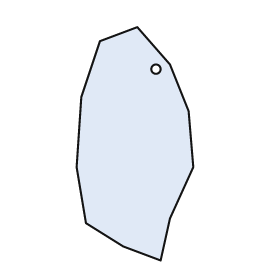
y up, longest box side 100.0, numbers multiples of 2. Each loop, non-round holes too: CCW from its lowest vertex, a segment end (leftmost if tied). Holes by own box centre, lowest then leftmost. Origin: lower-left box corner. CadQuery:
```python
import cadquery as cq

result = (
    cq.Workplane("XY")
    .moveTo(36.0, 0.0)
    .lineTo(40.0, 18.0)
    .lineTo(50.0, 40.0)
    .lineTo(48.0, 64.0)
    .lineTo(40.0, 84.0)
    .lineTo(26.0, 100.0)
    .lineTo(10.0, 94.0)
    .lineTo(2.0, 70.0)
    .lineTo(0.0, 40.0)
    .lineTo(4.0, 16.0)
    .lineTo(20.0, 6.0)
    .close()
    .moveTo(34.0, 82.0)
    .circle(2.0)
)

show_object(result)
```